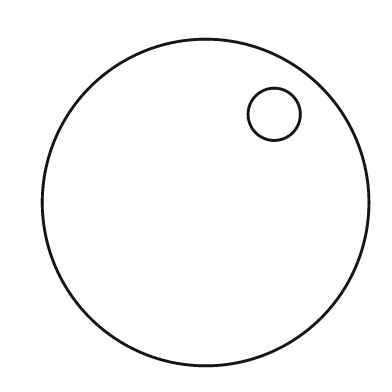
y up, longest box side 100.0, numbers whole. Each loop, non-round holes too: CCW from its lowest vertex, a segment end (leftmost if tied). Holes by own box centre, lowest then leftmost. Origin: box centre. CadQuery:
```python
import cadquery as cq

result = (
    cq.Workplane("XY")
    .moveTo(0.0, 0.0)
    .circle(50.0)
    .moveTo(21.0, 27.0)
    .circle(8.0)
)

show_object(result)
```